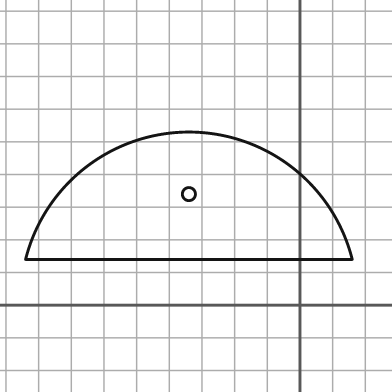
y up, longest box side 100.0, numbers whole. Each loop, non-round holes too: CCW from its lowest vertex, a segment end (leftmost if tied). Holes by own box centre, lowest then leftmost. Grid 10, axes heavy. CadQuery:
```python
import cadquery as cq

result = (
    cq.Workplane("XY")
    .moveTo(-84.0, 14.0)
    .lineTo(16.0, 14.0)
    .threePointArc((-34.0, 53.0), (-84.0, 14.0))
    .close()
    .moveTo(-34.0, 34.0)
    .circle(2.0)
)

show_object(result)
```